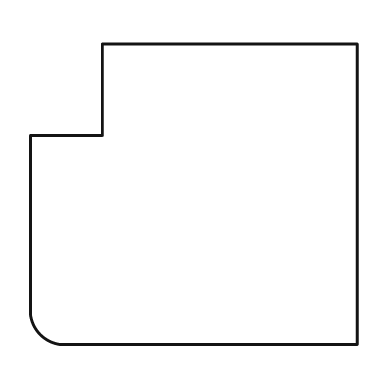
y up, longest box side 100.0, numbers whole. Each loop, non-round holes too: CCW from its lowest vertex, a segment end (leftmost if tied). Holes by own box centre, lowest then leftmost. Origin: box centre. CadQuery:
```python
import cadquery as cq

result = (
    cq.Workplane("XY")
    .moveTo(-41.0, -46.0)
    .lineTo(50.0, -46.0)
    .lineTo(50.0, 46.0)
    .lineTo(-28.0, 46.0)
    .lineTo(-28.0, 18.0)
    .lineTo(-50.0, 18.0)
    .lineTo(-50.0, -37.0)
    .threePointArc((-47.0, -43.0), (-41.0, -46.0))
    .close()
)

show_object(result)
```